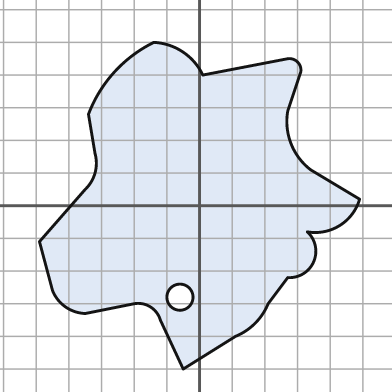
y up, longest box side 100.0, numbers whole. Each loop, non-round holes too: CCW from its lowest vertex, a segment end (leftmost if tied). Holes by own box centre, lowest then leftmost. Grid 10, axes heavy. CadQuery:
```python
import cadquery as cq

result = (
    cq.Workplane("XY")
    .moveTo(-5.0, -50.0)
    .lineTo(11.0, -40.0)
    .threePointArc((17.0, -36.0), (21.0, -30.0))
    .lineTo(27.0, -22.0)
    .threePointArc((35.0, -17.0), (33.0, -8.0))
    .threePointArc((43.0, -6.0), (49.0, 2.0))
    .lineTo(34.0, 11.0)
    .threePointArc((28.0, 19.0), (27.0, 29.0))
    .lineTo(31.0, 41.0)
    .threePointArc((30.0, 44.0), (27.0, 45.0))
    .lineTo(1.0, 40.0)
    .threePointArc((-5.0, 47.0), (-14.0, 50.0))
    .threePointArc((-26.0, 41.0), (-34.0, 28.0))
    .lineTo(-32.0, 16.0)
    .threePointArc((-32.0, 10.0), (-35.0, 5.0))
    .lineTo(-49.0, -11.0)
    .lineTo(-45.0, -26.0)
    .threePointArc((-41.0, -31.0), (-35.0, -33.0))
    .lineTo(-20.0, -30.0)
    .threePointArc((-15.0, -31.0), (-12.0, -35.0))
    .close()
    .moveTo(-6.0, -28.0)
    .circle(4.0)
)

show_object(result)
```